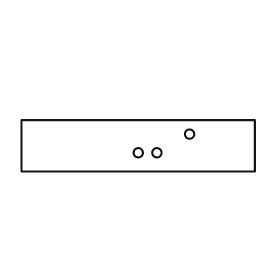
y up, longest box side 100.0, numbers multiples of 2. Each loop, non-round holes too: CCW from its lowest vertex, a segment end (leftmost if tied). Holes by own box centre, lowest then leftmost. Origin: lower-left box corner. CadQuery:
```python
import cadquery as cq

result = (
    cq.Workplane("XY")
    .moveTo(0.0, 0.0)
    .lineTo(100.0, 0.0)
    .lineTo(100.0, 22.0)
    .lineTo(0.0, 22.0)
    .close()
    .moveTo(50.0, 8.0)
    .circle(2.0)
    .moveTo(58.0, 8.0)
    .circle(2.0)
    .moveTo(72.0, 16.0)
    .circle(2.0)
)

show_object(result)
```